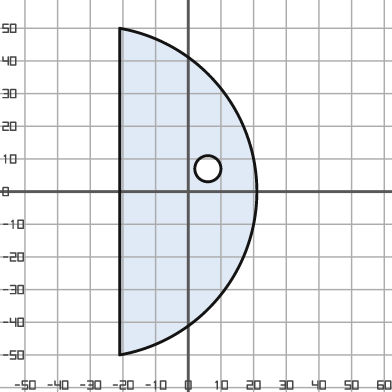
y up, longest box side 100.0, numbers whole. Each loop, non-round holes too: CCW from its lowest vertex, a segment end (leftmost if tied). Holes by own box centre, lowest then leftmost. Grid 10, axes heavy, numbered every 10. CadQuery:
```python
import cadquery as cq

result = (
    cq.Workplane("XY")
    .moveTo(-21.0, -50.0)
    .threePointArc((21.0, 0.0), (-21.0, 50.0))
    .close()
    .moveTo(6.0, 7.0)
    .circle(4.0)
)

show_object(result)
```